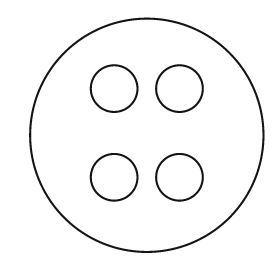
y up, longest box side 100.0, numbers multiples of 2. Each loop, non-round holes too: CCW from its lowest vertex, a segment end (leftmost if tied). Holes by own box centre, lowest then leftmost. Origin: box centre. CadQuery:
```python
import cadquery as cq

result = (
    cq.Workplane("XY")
    .moveTo(0.0, 0.0)
    .circle(50.0)
    .moveTo(-14.0, -18.0)
    .circle(10.0)
    .moveTo(14.0, -18.0)
    .circle(10.0)
    .moveTo(-14.0, 20.0)
    .circle(10.0)
    .moveTo(14.0, 20.0)
    .circle(10.0)
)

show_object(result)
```